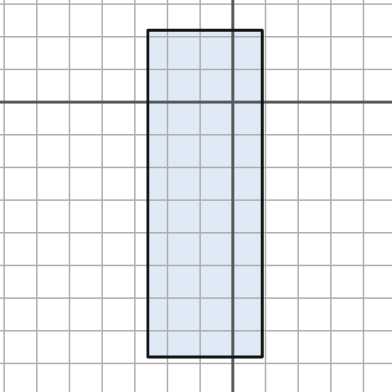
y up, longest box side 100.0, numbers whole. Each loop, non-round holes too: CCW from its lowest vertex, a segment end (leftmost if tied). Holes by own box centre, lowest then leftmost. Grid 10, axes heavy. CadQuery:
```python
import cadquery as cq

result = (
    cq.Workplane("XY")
    .moveTo(-26.0, -78.0)
    .lineTo(9.0, -78.0)
    .lineTo(9.0, 22.0)
    .lineTo(-26.0, 22.0)
    .close()
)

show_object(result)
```